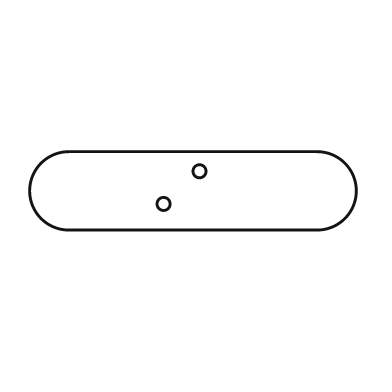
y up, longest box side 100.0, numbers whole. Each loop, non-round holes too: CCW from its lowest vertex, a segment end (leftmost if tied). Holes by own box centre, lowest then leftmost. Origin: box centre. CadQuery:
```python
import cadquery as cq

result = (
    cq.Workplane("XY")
    .moveTo(-38.0, -12.0)
    .lineTo(38.0, -12.0)
    .threePointArc((50.0, 0.0), (38.0, 12.0))
    .lineTo(-38.0, 12.0)
    .threePointArc((-50.0, 0.0), (-38.0, -12.0))
    .close()
    .moveTo(-9.0, -4.0)
    .circle(2.0)
    .moveTo(2.0, 6.0)
    .circle(2.0)
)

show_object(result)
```